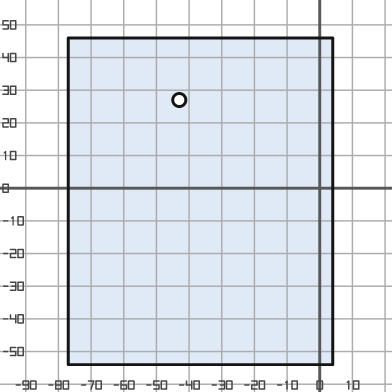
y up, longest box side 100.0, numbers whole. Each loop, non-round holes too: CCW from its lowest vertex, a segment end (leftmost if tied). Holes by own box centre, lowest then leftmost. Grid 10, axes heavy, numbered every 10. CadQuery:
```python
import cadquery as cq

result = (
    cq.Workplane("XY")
    .moveTo(-77.0, -54.0)
    .lineTo(4.0, -54.0)
    .lineTo(4.0, 46.0)
    .lineTo(-77.0, 46.0)
    .close()
    .moveTo(-43.0, 27.0)
    .circle(2.0)
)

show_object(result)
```